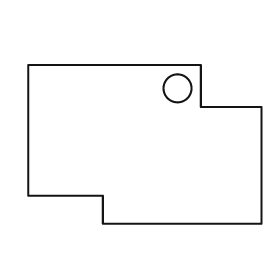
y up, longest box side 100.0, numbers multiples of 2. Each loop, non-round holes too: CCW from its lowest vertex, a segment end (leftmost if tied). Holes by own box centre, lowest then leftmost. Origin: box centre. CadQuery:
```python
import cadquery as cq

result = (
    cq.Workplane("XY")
    .moveTo(-18.0, -34.0)
    .lineTo(50.0, -34.0)
    .lineTo(50.0, 16.0)
    .lineTo(24.0, 16.0)
    .lineTo(24.0, 34.0)
    .lineTo(-50.0, 34.0)
    .lineTo(-50.0, -22.0)
    .lineTo(-18.0, -22.0)
    .close()
    .moveTo(14.0, 24.0)
    .circle(6.0)
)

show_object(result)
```